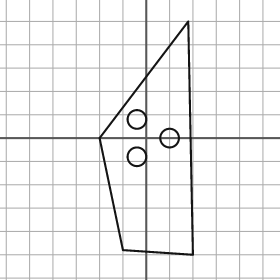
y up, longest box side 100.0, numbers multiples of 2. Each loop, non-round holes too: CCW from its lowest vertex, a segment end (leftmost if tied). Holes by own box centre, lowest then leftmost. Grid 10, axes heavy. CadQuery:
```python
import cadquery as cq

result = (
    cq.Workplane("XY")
    .moveTo(20.0, -50.0)
    .lineTo(18.0, 50.0)
    .lineTo(-20.0, 0.0)
    .lineTo(-10.0, -48.0)
    .close()
    .moveTo(-4.0, -8.0)
    .circle(4.0)
    .moveTo(10.0, 0.0)
    .circle(4.0)
    .moveTo(-4.0, 8.0)
    .circle(4.0)
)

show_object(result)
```